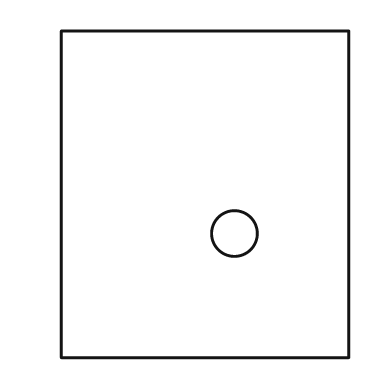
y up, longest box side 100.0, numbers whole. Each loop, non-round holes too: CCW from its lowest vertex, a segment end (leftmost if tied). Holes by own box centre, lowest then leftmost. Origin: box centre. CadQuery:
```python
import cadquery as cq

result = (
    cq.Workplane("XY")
    .moveTo(-44.0, -50.0)
    .lineTo(44.0, -50.0)
    .lineTo(44.0, 50.0)
    .lineTo(-44.0, 50.0)
    .close()
    .moveTo(9.0, -12.0)
    .circle(7.0)
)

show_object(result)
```